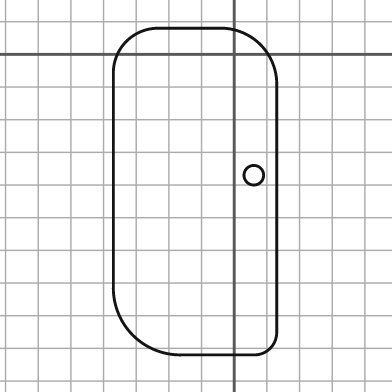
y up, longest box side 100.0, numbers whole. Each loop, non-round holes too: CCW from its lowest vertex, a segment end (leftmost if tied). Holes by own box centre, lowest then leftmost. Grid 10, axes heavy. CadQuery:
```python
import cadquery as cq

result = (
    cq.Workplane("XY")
    .moveTo(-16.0, -92.0)
    .lineTo(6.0, -92.0)
    .threePointArc((11.0, -90.0), (13.0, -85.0))
    .lineTo(13.0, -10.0)
    .threePointArc((8.0, 3.0), (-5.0, 8.0))
    .lineTo(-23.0, 8.0)
    .threePointArc((-33.0, 4.0), (-37.0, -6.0))
    .lineTo(-37.0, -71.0)
    .threePointArc((-31.0, -86.0), (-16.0, -92.0))
    .close()
    .moveTo(6.0, -37.0)
    .circle(3.0)
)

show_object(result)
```